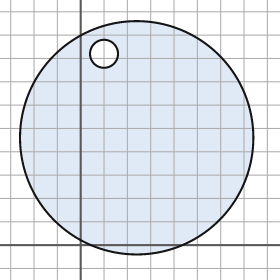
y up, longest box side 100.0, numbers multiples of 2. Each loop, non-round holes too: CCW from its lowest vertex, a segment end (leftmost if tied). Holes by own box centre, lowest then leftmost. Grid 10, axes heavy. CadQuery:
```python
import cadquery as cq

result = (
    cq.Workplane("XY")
    .moveTo(24.0, 46.0)
    .circle(50.0)
    .moveTo(10.0, 82.0)
    .circle(6.0)
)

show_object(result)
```